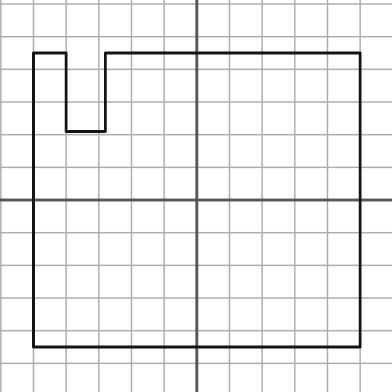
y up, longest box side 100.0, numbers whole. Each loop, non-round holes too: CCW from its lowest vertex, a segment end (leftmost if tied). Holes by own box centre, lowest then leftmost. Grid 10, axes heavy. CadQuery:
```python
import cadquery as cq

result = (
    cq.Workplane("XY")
    .moveTo(-50.0, -45.0)
    .lineTo(50.0, -45.0)
    .lineTo(50.0, 45.0)
    .lineTo(-28.0, 45.0)
    .lineTo(-28.0, 21.0)
    .lineTo(-40.0, 21.0)
    .lineTo(-40.0, 45.0)
    .lineTo(-50.0, 45.0)
    .close()
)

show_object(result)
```